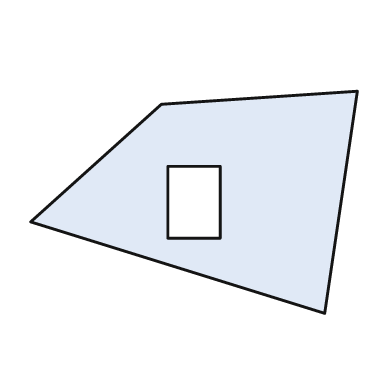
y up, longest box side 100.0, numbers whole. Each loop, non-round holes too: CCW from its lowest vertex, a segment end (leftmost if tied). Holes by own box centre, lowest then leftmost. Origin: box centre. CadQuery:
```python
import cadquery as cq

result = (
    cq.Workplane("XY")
    .moveTo(40.0, -34.0)
    .lineTo(50.0, 34.0)
    .lineTo(-10.0, 30.0)
    .lineTo(-50.0, -6.0)
    .close()
    .moveTo(-8.0, -11.0)
    .lineTo(8.0, -11.0)
    .lineTo(8.0, 11.0)
    .lineTo(-8.0, 11.0)
    .close()
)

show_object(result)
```